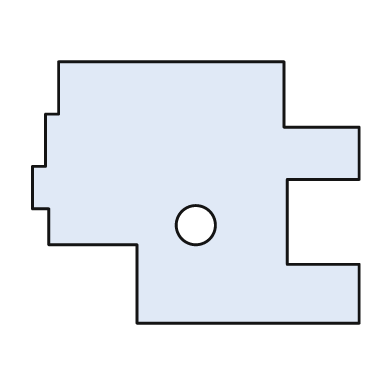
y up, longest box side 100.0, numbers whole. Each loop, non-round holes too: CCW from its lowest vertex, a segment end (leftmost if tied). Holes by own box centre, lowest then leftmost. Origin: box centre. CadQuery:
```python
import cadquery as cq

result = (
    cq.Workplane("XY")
    .moveTo(-18.0, -40.0)
    .lineTo(50.0, -40.0)
    .lineTo(50.0, -22.0)
    .lineTo(28.0, -22.0)
    .lineTo(28.0, 4.0)
    .lineTo(50.0, 4.0)
    .lineTo(50.0, 20.0)
    .lineTo(27.0, 20.0)
    .lineTo(27.0, 40.0)
    .lineTo(-42.0, 40.0)
    .lineTo(-42.0, 24.0)
    .lineTo(-46.0, 24.0)
    .lineTo(-46.0, 8.0)
    .lineTo(-50.0, 8.0)
    .lineTo(-50.0, -5.0)
    .lineTo(-45.0, -5.0)
    .lineTo(-45.0, -16.0)
    .lineTo(-18.0, -16.0)
    .close()
    .moveTo(0.0, -10.0)
    .circle(6.0)
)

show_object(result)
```